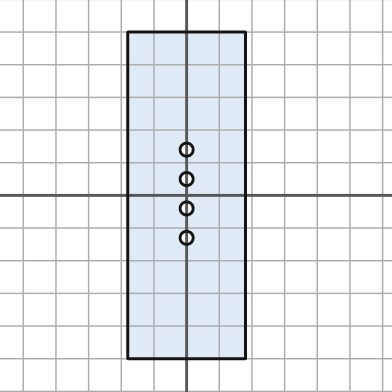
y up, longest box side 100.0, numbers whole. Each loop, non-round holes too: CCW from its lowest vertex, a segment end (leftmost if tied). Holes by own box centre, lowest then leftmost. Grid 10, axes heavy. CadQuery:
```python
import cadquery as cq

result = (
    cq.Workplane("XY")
    .moveTo(-18.0, -50.0)
    .lineTo(18.0, -50.0)
    .lineTo(18.0, 50.0)
    .lineTo(-18.0, 50.0)
    .close()
    .moveTo(0.0, -13.0)
    .circle(2.0)
    .moveTo(0.0, -4.0)
    .circle(2.0)
    .moveTo(0.0, 5.0)
    .circle(2.0)
    .moveTo(0.0, 14.0)
    .circle(2.0)
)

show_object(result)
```